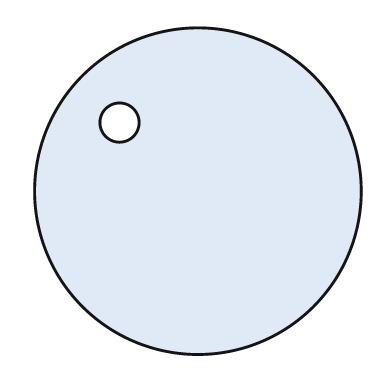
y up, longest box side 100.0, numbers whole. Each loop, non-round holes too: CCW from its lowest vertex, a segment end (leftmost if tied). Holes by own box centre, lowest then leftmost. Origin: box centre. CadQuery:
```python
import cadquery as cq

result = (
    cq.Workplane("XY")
    .moveTo(0.0, 0.0)
    .circle(50.0)
    .moveTo(-24.0, 21.0)
    .circle(6.0)
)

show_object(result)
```